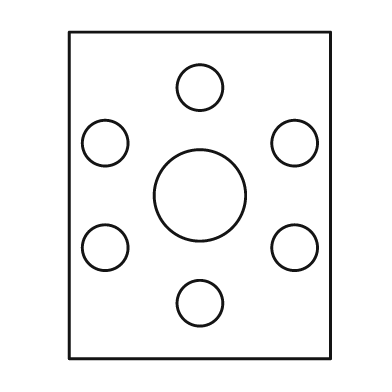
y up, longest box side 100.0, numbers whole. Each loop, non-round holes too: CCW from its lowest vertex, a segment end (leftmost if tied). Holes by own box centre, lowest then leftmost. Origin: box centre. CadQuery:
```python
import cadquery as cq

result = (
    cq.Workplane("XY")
    .moveTo(-40.0, -50.0)
    .lineTo(40.0, -50.0)
    .lineTo(40.0, 50.0)
    .lineTo(-40.0, 50.0)
    .close()
    .moveTo(0.0, -33.0)
    .circle(7.0)
    .moveTo(-29.0, -16.0)
    .circle(7.0)
    .moveTo(29.0, -16.0)
    .circle(7.0)
    .moveTo(0.0, 0.0)
    .circle(14.0)
    .moveTo(-29.0, 16.0)
    .circle(7.0)
    .moveTo(29.0, 16.0)
    .circle(7.0)
    .moveTo(0.0, 33.0)
    .circle(7.0)
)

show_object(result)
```